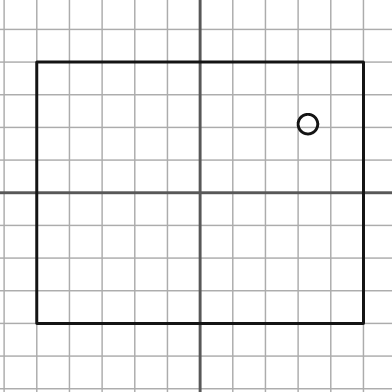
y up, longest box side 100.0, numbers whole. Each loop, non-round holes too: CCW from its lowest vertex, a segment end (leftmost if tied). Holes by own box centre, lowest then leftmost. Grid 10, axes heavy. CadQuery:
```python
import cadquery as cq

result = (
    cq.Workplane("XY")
    .moveTo(-50.0, -40.0)
    .lineTo(50.0, -40.0)
    .lineTo(50.0, 40.0)
    .lineTo(-50.0, 40.0)
    .close()
    .moveTo(33.0, 21.0)
    .circle(3.0)
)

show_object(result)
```